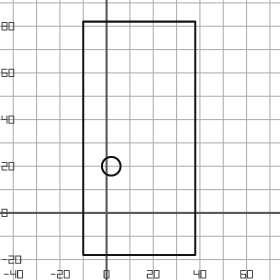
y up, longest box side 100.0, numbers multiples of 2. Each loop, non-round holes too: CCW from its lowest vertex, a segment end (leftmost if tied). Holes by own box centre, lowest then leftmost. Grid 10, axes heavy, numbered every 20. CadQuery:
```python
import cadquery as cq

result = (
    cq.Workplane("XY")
    .moveTo(-10.0, -18.0)
    .lineTo(38.0, -18.0)
    .lineTo(38.0, 82.0)
    .lineTo(-10.0, 82.0)
    .close()
    .moveTo(2.0, 20.0)
    .circle(4.0)
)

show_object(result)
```